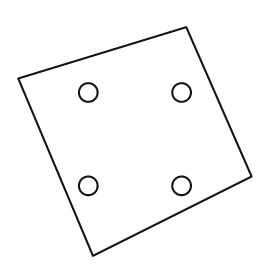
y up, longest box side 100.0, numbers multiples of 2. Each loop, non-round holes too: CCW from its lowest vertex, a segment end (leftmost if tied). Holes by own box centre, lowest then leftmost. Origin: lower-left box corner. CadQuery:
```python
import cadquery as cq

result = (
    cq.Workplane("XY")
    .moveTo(32.0, 0.0)
    .lineTo(100.0, 34.0)
    .lineTo(72.0, 98.0)
    .lineTo(0.0, 76.0)
    .close()
    .moveTo(30.0, 30.0)
    .circle(4.0)
    .moveTo(70.0, 30.0)
    .circle(4.0)
    .moveTo(30.0, 70.0)
    .circle(4.0)
    .moveTo(70.0, 70.0)
    .circle(4.0)
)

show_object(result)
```